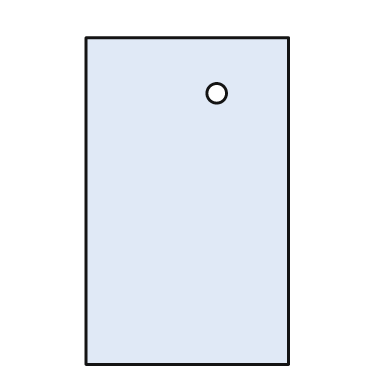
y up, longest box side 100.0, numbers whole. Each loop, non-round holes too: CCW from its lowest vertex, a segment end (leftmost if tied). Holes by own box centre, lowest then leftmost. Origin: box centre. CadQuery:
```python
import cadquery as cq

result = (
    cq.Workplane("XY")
    .moveTo(-31.0, -50.0)
    .lineTo(31.0, -50.0)
    .lineTo(31.0, 50.0)
    .lineTo(-31.0, 50.0)
    .close()
    .moveTo(9.0, 33.0)
    .circle(3.0)
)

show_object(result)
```